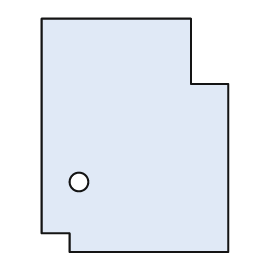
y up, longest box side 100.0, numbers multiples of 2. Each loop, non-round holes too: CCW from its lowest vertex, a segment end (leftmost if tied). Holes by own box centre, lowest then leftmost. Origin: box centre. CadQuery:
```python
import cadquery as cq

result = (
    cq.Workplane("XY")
    .moveTo(-28.0, -50.0)
    .lineTo(40.0, -50.0)
    .lineTo(40.0, 22.0)
    .lineTo(24.0, 22.0)
    .lineTo(24.0, 50.0)
    .lineTo(-40.0, 50.0)
    .lineTo(-40.0, -42.0)
    .lineTo(-28.0, -42.0)
    .close()
    .moveTo(-24.0, -20.0)
    .circle(4.0)
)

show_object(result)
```